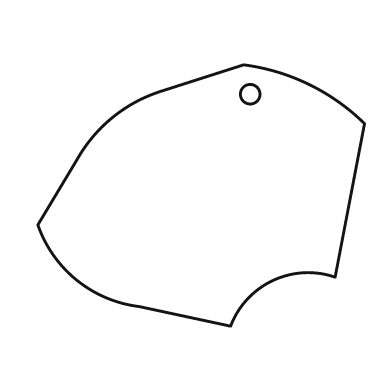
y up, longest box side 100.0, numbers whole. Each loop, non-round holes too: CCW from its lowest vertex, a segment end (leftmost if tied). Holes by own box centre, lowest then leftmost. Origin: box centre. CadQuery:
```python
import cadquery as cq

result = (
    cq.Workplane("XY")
    .moveTo(9.0, -40.0)
    .threePointArc((22.0, -26.0), (41.0, -25.0))
    .lineTo(50.0, 22.0)
    .threePointArc((33.0, 34.0), (13.0, 40.0))
    .lineTo(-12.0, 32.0)
    .threePointArc((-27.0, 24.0), (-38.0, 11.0))
    .lineTo(-50.0, -9.0)
    .threePointArc((-38.0, -26.0), (-19.0, -34.0))
    .close()
    .moveTo(15.0, 31.0)
    .circle(3.0)
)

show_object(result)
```